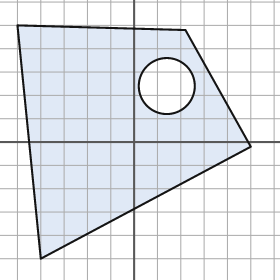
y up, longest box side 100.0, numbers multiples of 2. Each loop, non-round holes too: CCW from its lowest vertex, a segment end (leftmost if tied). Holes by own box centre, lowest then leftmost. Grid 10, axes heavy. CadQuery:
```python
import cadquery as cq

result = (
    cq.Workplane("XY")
    .moveTo(-40.0, -50.0)
    .lineTo(50.0, -2.0)
    .lineTo(22.0, 48.0)
    .lineTo(-50.0, 50.0)
    .close()
    .moveTo(14.0, 24.0)
    .circle(12.0)
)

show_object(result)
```